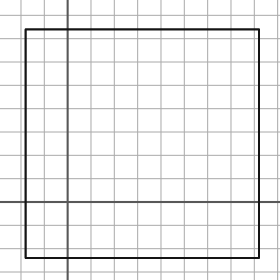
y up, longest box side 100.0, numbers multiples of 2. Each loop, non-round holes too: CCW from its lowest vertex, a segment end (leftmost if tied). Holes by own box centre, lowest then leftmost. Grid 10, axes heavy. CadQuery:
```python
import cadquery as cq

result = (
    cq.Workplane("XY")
    .moveTo(-18.0, -24.0)
    .lineTo(82.0, -24.0)
    .lineTo(82.0, 74.0)
    .lineTo(-18.0, 74.0)
    .close()
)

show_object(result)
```